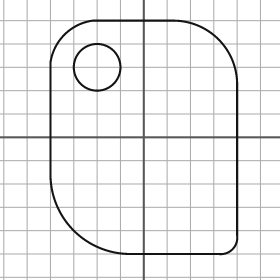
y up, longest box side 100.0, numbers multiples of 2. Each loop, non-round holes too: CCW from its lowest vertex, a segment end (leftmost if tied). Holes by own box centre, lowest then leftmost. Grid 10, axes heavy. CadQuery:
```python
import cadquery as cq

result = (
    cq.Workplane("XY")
    .moveTo(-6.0, -50.0)
    .lineTo(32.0, -50.0)
    .threePointArc((38.0, -48.0), (40.0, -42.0))
    .lineTo(40.0, 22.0)
    .threePointArc((32.0, 42.0), (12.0, 50.0))
    .lineTo(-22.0, 50.0)
    .threePointArc((-34.0, 44.0), (-40.0, 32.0))
    .lineTo(-40.0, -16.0)
    .threePointArc((-30.0, -40.0), (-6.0, -50.0))
    .close()
    .moveTo(-20.0, 30.0)
    .circle(10.0)
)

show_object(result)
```